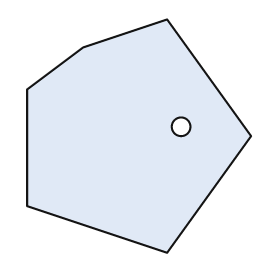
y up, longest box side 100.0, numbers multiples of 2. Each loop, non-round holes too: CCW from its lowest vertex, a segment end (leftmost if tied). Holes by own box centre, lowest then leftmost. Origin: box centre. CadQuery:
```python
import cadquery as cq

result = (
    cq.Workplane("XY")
    .moveTo(12.0, -50.0)
    .lineTo(48.0, 0.0)
    .lineTo(12.0, 50.0)
    .lineTo(-24.0, 38.0)
    .lineTo(-48.0, 20.0)
    .lineTo(-48.0, -30.0)
    .close()
    .moveTo(18.0, 4.0)
    .circle(4.0)
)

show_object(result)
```